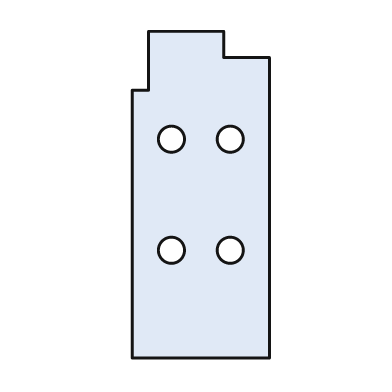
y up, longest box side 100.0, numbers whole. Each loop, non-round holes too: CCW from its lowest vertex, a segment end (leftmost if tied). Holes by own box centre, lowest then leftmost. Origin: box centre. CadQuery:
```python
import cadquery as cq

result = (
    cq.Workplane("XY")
    .moveTo(-21.0, -50.0)
    .lineTo(21.0, -50.0)
    .lineTo(21.0, 42.0)
    .lineTo(7.0, 42.0)
    .lineTo(7.0, 50.0)
    .lineTo(-16.0, 50.0)
    .lineTo(-16.0, 32.0)
    .lineTo(-21.0, 32.0)
    .close()
    .moveTo(-9.0, -17.0)
    .circle(4.0)
    .moveTo(9.0, -17.0)
    .circle(4.0)
    .moveTo(-9.0, 17.0)
    .circle(4.0)
    .moveTo(9.0, 17.0)
    .circle(4.0)
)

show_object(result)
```